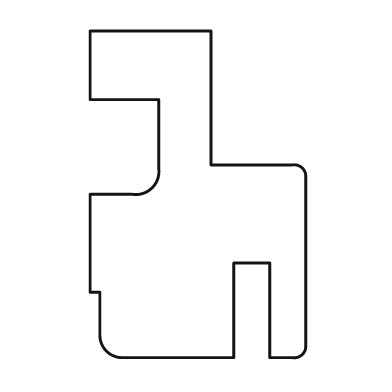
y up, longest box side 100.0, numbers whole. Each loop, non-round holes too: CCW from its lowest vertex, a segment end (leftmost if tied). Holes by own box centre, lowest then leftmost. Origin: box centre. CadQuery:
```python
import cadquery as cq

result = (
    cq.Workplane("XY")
    .moveTo(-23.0, -50.0)
    .lineTo(11.0, -50.0)
    .lineTo(11.0, -21.0)
    .lineTo(22.0, -21.0)
    .lineTo(22.0, -50.0)
    .lineTo(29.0, -50.0)
    .threePointArc((32.0, -49.0), (33.0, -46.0))
    .lineTo(33.0, 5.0)
    .threePointArc((32.0, 8.0), (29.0, 9.0))
    .lineTo(4.0, 9.0)
    .lineTo(4.0, 50.0)
    .lineTo(-33.0, 50.0)
    .lineTo(-33.0, 29.0)
    .lineTo(-12.0, 29.0)
    .lineTo(-12.0, 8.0)
    .threePointArc((-14.0, 2.0), (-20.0, 0.0))
    .lineTo(-33.0, 0.0)
    .lineTo(-33.0, -30.0)
    .lineTo(-30.0, -30.0)
    .lineTo(-30.0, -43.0)
    .threePointArc((-28.0, -48.0), (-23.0, -50.0))
    .close()
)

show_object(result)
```